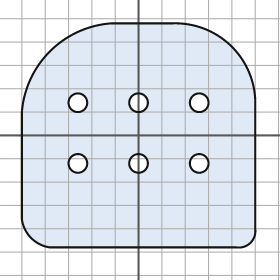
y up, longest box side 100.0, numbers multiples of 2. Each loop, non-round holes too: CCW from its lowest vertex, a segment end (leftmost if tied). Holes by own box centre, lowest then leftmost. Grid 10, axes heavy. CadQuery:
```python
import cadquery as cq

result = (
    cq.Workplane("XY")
    .moveTo(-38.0, -48.0)
    .lineTo(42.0, -48.0)
    .threePointArc((48.0, -46.0), (50.0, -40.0))
    .lineTo(50.0, 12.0)
    .threePointArc((40.0, 38.0), (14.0, 48.0))
    .lineTo(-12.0, 48.0)
    .threePointArc((-38.0, 36.0), (-50.0, 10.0))
    .lineTo(-50.0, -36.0)
    .threePointArc((-46.0, -44.0), (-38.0, -48.0))
    .close()
    .moveTo(-26.0, -12.0)
    .circle(4.0)
    .moveTo(0.0, -12.0)
    .circle(4.0)
    .moveTo(26.0, -12.0)
    .circle(4.0)
    .moveTo(-26.0, 14.0)
    .circle(4.0)
    .moveTo(0.0, 14.0)
    .circle(4.0)
    .moveTo(26.0, 14.0)
    .circle(4.0)
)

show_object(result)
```